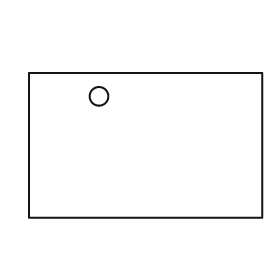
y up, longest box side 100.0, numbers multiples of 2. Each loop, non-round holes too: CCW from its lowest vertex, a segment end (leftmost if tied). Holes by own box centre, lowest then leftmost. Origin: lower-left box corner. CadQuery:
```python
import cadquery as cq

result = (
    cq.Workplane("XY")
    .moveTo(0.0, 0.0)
    .lineTo(100.0, 0.0)
    .lineTo(100.0, 62.0)
    .lineTo(0.0, 62.0)
    .close()
    .moveTo(30.0, 52.0)
    .circle(4.0)
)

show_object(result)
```